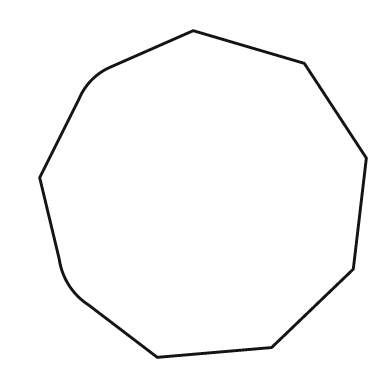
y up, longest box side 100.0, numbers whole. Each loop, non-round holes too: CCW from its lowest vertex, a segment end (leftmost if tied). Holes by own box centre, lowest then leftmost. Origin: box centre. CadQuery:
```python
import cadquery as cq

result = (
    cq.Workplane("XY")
    .moveTo(-14.0, -50.0)
    .lineTo(21.0, -47.0)
    .lineTo(46.0, -23.0)
    .lineTo(50.0, 11.0)
    .lineTo(31.0, 40.0)
    .lineTo(-3.0, 50.0)
    .lineTo(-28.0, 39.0)
    .threePointArc((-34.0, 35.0), (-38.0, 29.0))
    .lineTo(-50.0, 5.0)
    .lineTo(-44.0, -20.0)
    .threePointArc((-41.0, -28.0), (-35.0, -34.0))
    .close()
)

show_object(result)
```